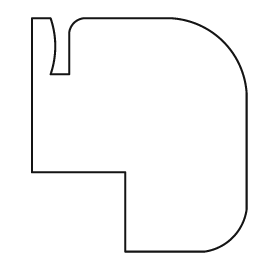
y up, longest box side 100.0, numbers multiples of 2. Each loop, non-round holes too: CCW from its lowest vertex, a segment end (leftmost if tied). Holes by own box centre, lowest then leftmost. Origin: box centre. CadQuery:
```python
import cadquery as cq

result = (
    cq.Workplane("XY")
    .moveTo(-6.0, -50.0)
    .lineTo(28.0, -50.0)
    .threePointArc((40.0, -44.0), (46.0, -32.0))
    .lineTo(46.0, 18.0)
    .threePointArc((36.0, 40.0), (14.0, 50.0))
    .lineTo(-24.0, 50.0)
    .threePointArc((-28.0, 48.0), (-30.0, 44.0))
    .lineTo(-30.0, 26.0)
    .lineTo(-38.0, 26.0)
    .threePointArc((-36.0, 38.0), (-38.0, 50.0))
    .lineTo(-46.0, 50.0)
    .lineTo(-46.0, -16.0)
    .lineTo(-6.0, -16.0)
    .close()
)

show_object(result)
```